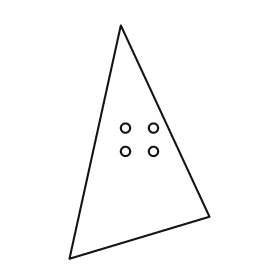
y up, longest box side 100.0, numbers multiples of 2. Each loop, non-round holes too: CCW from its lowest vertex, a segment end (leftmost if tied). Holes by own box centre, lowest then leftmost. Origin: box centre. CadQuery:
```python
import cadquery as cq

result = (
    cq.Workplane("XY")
    .moveTo(-30.0, -50.0)
    .lineTo(30.0, -32.0)
    .lineTo(-8.0, 50.0)
    .close()
    .moveTo(-6.0, -4.0)
    .circle(2.0)
    .moveTo(6.0, -4.0)
    .circle(2.0)
    .moveTo(-6.0, 6.0)
    .circle(2.0)
    .moveTo(6.0, 6.0)
    .circle(2.0)
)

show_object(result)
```